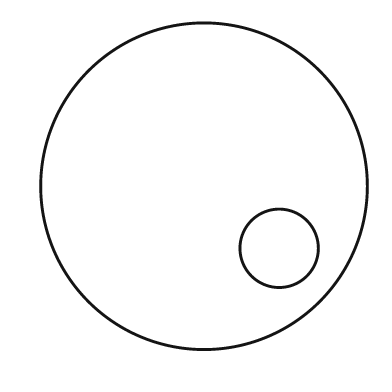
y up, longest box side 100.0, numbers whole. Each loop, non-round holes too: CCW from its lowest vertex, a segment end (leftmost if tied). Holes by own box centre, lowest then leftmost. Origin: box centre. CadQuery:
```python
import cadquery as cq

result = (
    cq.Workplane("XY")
    .moveTo(0.0, 0.0)
    .circle(50.0)
    .moveTo(23.0, -19.0)
    .circle(12.0)
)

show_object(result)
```